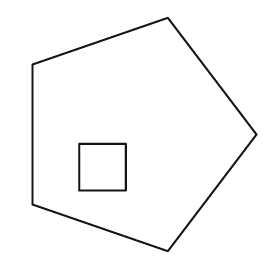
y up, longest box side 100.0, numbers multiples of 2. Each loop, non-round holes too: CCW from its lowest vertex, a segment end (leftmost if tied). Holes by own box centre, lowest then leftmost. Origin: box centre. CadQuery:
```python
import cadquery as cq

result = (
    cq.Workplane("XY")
    .moveTo(10.0, -50.0)
    .lineTo(48.0, 0.0)
    .lineTo(10.0, 50.0)
    .lineTo(-48.0, 30.0)
    .lineTo(-48.0, -30.0)
    .close()
    .moveTo(-28.0, -24.0)
    .lineTo(-8.0, -24.0)
    .lineTo(-8.0, -4.0)
    .lineTo(-28.0, -4.0)
    .close()
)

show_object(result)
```